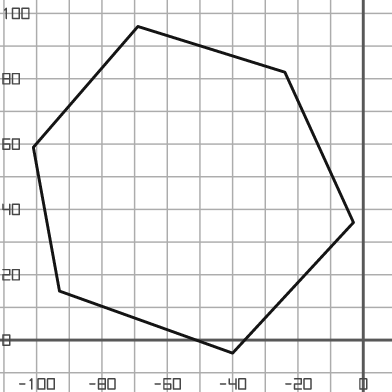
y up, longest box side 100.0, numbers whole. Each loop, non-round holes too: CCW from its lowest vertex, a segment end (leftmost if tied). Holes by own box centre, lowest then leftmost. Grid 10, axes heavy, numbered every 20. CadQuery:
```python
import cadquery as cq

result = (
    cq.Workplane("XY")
    .moveTo(-40.0, -4.0)
    .lineTo(-3.0, 36.0)
    .lineTo(-24.0, 82.0)
    .lineTo(-69.0, 96.0)
    .lineTo(-101.0, 59.0)
    .lineTo(-93.0, 15.0)
    .close()
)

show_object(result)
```